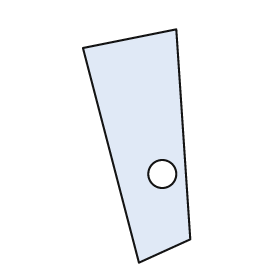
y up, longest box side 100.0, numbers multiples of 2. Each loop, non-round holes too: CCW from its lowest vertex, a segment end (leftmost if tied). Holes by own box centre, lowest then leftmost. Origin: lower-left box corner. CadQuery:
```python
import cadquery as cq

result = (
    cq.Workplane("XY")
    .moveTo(24.0, 0.0)
    .lineTo(46.0, 10.0)
    .lineTo(40.0, 100.0)
    .lineTo(0.0, 92.0)
    .close()
    .moveTo(34.0, 38.0)
    .circle(6.0)
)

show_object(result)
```